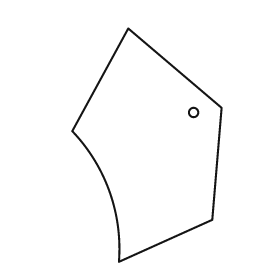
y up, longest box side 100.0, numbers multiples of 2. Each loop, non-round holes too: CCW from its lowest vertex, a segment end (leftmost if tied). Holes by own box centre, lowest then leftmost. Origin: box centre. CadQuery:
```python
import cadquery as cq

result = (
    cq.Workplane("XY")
    .moveTo(-12.0, -50.0)
    .lineTo(28.0, -32.0)
    .lineTo(32.0, 16.0)
    .lineTo(-8.0, 50.0)
    .lineTo(-32.0, 6.0)
    .threePointArc((-16.0, -20.0), (-12.0, -50.0))
    .close()
    .moveTo(20.0, 14.0)
    .circle(2.0)
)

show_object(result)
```